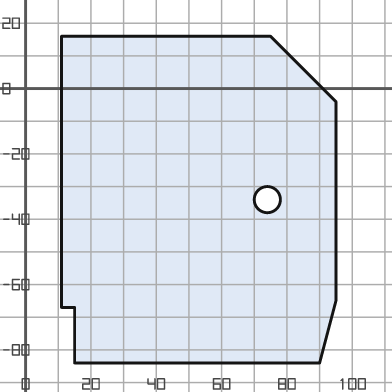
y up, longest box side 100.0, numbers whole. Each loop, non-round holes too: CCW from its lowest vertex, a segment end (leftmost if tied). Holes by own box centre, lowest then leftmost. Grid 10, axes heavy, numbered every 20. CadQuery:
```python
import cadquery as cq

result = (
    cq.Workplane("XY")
    .moveTo(15.0, -84.0)
    .lineTo(90.0, -84.0)
    .lineTo(95.0, -65.0)
    .lineTo(95.0, -4.0)
    .lineTo(75.0, 16.0)
    .lineTo(11.0, 16.0)
    .lineTo(11.0, -67.0)
    .lineTo(15.0, -67.0)
    .close()
    .moveTo(74.0, -34.0)
    .circle(4.0)
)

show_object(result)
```